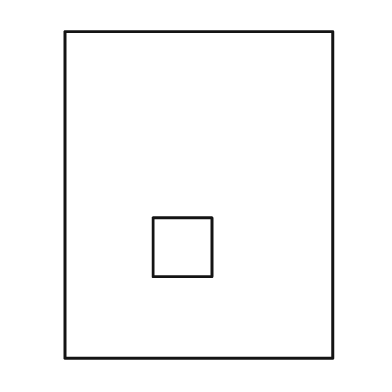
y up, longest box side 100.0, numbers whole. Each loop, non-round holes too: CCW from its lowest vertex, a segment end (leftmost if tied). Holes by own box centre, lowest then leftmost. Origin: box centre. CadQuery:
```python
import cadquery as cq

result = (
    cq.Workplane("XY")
    .moveTo(-41.0, -50.0)
    .lineTo(41.0, -50.0)
    .lineTo(41.0, 50.0)
    .lineTo(-41.0, 50.0)
    .close()
    .moveTo(-14.0, -25.0)
    .lineTo(4.0, -25.0)
    .lineTo(4.0, -7.0)
    .lineTo(-14.0, -7.0)
    .close()
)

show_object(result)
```